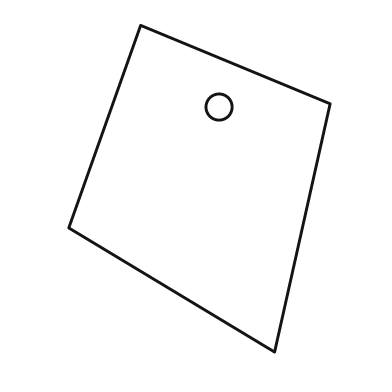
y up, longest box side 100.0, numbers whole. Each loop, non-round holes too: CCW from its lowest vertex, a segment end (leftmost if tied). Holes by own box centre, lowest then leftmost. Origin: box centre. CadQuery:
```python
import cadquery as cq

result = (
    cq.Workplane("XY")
    .moveTo(23.0, -50.0)
    .lineTo(40.0, 26.0)
    .lineTo(-18.0, 50.0)
    .lineTo(-40.0, -12.0)
    .close()
    .moveTo(6.0, 25.0)
    .circle(4.0)
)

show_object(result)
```